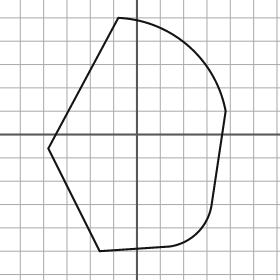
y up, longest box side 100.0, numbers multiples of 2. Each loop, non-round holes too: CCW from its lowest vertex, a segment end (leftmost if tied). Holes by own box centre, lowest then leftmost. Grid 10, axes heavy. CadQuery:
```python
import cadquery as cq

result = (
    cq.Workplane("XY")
    .moveTo(-16.0, -50.0)
    .lineTo(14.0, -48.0)
    .threePointArc((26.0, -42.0), (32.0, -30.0))
    .lineTo(38.0, 10.0)
    .threePointArc((22.0, 38.0), (-8.0, 50.0))
    .lineTo(-38.0, -6.0)
    .close()
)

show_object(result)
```